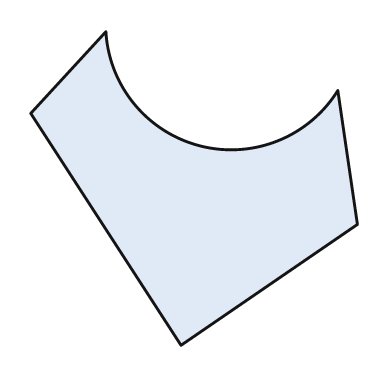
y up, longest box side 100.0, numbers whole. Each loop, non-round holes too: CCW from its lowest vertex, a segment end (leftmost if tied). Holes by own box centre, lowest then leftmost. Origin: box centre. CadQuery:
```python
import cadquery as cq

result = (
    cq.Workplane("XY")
    .moveTo(-4.0, -48.0)
    .lineTo(50.0, -11.0)
    .lineTo(44.0, 30.0)
    .threePointArc((2.0, 13.0), (-27.0, 48.0))
    .lineTo(-50.0, 23.0)
    .close()
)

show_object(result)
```